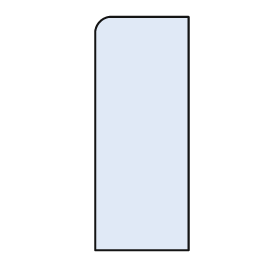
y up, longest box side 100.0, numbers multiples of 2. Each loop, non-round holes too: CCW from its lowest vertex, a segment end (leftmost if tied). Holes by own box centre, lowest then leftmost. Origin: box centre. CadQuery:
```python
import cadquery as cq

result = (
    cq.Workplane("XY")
    .moveTo(-20.0, -50.0)
    .lineTo(20.0, -50.0)
    .lineTo(20.0, 50.0)
    .lineTo(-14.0, 50.0)
    .threePointArc((-18.0, 48.0), (-20.0, 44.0))
    .close()
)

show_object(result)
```